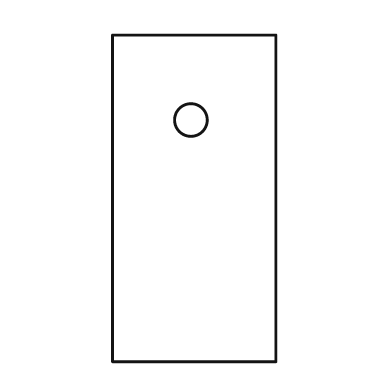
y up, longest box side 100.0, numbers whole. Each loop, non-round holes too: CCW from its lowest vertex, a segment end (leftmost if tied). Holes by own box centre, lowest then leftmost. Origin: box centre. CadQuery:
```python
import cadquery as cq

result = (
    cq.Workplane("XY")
    .moveTo(-25.0, -50.0)
    .lineTo(25.0, -50.0)
    .lineTo(25.0, 50.0)
    .lineTo(-25.0, 50.0)
    .close()
    .moveTo(-1.0, 24.0)
    .circle(5.0)
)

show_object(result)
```